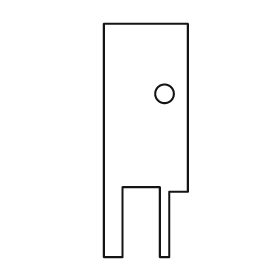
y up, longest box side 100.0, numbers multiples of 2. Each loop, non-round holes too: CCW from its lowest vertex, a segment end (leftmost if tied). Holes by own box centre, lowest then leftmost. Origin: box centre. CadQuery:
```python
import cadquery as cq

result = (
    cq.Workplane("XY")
    .moveTo(-18.0, -50.0)
    .lineTo(-10.0, -50.0)
    .lineTo(-10.0, -20.0)
    .lineTo(6.0, -20.0)
    .lineTo(6.0, -50.0)
    .lineTo(10.0, -50.0)
    .lineTo(10.0, -22.0)
    .lineTo(18.0, -22.0)
    .lineTo(18.0, 50.0)
    .lineTo(-18.0, 50.0)
    .close()
    .moveTo(8.0, 20.0)
    .circle(4.0)
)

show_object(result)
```